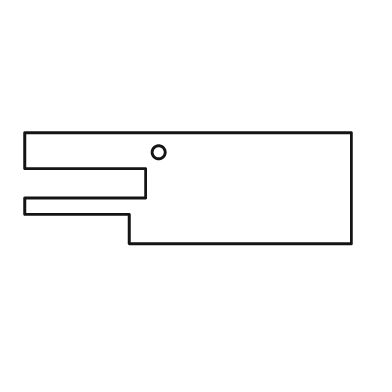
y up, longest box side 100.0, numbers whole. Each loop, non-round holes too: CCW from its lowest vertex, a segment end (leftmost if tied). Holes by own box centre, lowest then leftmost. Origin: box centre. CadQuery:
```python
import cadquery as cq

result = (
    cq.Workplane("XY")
    .moveTo(-18.0, -17.0)
    .lineTo(50.0, -17.0)
    .lineTo(50.0, 17.0)
    .lineTo(-50.0, 17.0)
    .lineTo(-50.0, 6.0)
    .lineTo(-13.0, 6.0)
    .lineTo(-13.0, -3.0)
    .lineTo(-50.0, -3.0)
    .lineTo(-50.0, -8.0)
    .lineTo(-18.0, -8.0)
    .close()
    .moveTo(-9.0, 11.0)
    .circle(2.0)
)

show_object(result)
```